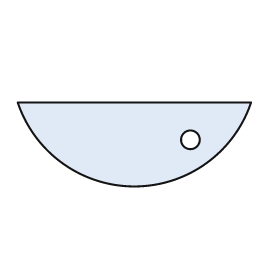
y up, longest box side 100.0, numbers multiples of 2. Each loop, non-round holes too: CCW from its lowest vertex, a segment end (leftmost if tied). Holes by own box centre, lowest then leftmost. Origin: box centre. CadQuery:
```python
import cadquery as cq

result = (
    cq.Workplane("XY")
    .moveTo(-50.0, 18.0)
    .threePointArc((0.0, -18.0), (50.0, 18.0))
    .close()
    .moveTo(24.0, 2.0)
    .circle(4.0)
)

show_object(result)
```